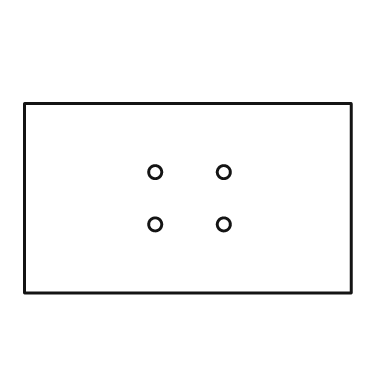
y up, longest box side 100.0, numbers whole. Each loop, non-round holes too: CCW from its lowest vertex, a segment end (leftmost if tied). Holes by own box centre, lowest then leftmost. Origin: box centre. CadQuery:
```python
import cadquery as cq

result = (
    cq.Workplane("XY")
    .moveTo(-50.0, -29.0)
    .lineTo(50.0, -29.0)
    .lineTo(50.0, 29.0)
    .lineTo(-50.0, 29.0)
    .close()
    .moveTo(-10.0, -8.0)
    .circle(2.0)
    .moveTo(11.0, -8.0)
    .circle(2.0)
    .moveTo(-10.0, 8.0)
    .circle(2.0)
    .moveTo(11.0, 8.0)
    .circle(2.0)
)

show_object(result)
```